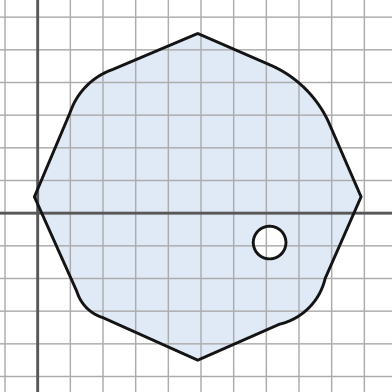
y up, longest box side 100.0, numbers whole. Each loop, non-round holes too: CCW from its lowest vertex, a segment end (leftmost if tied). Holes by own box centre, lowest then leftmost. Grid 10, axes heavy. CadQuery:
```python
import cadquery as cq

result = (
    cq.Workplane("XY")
    .moveTo(49.0, -45.0)
    .lineTo(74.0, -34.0)
    .threePointArc((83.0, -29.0), (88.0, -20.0))
    .lineTo(99.0, 5.0)
    .lineTo(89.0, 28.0)
    .threePointArc((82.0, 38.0), (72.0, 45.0))
    .lineTo(49.0, 55.0)
    .lineTo(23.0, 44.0)
    .threePointArc((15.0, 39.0), (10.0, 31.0))
    .lineTo(-1.0, 5.0)
    .lineTo(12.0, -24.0)
    .threePointArc((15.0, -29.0), (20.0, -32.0))
    .close()
    .moveTo(71.0, -9.0)
    .circle(5.0)
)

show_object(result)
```